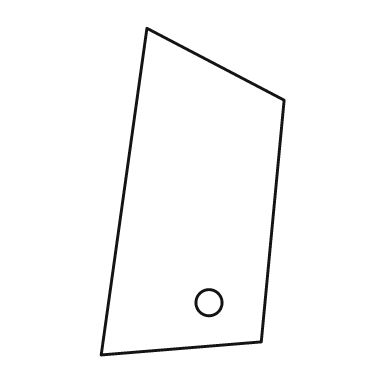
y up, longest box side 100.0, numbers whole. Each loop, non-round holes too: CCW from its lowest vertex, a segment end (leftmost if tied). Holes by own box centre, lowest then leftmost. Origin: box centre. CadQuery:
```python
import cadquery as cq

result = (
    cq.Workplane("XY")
    .moveTo(-28.0, -50.0)
    .lineTo(21.0, -46.0)
    .lineTo(28.0, 28.0)
    .lineTo(-14.0, 50.0)
    .close()
    .moveTo(5.0, -34.0)
    .circle(4.0)
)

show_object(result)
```